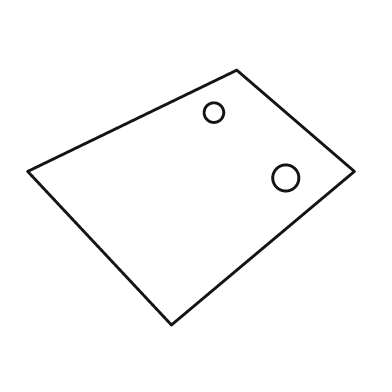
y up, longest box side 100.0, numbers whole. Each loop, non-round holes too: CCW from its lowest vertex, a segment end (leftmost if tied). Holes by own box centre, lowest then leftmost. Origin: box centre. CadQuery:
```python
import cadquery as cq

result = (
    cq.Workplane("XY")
    .moveTo(-6.0, -39.0)
    .lineTo(50.0, 8.0)
    .lineTo(14.0, 39.0)
    .lineTo(-50.0, 8.0)
    .close()
    .moveTo(29.0, 6.0)
    .circle(4.0)
    .moveTo(7.0, 26.0)
    .circle(3.0)
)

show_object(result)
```